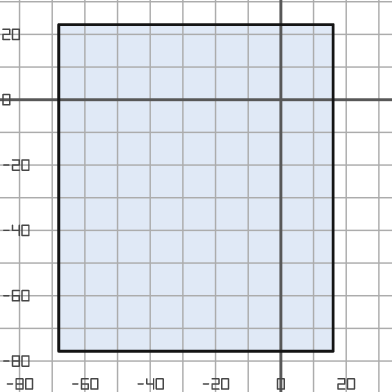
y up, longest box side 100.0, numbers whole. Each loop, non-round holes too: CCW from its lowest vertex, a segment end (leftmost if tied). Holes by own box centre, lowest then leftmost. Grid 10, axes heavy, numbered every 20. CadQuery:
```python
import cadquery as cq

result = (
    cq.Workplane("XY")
    .moveTo(-68.0, -77.0)
    .lineTo(16.0, -77.0)
    .lineTo(16.0, 23.0)
    .lineTo(-68.0, 23.0)
    .close()
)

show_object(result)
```